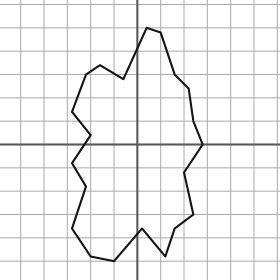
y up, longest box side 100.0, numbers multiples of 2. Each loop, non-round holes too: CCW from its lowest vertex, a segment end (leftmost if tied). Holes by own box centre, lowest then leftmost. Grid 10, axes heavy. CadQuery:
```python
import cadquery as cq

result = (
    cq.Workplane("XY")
    .moveTo(-10.0, -50.0)
    .lineTo(2.0, -36.0)
    .lineTo(12.0, -48.0)
    .lineTo(16.0, -36.0)
    .lineTo(24.0, -30.0)
    .lineTo(20.0, -12.0)
    .lineTo(28.0, 0.0)
    .lineTo(24.0, 10.0)
    .lineTo(22.0, 24.0)
    .lineTo(16.0, 30.0)
    .lineTo(10.0, 48.0)
    .lineTo(4.0, 50.0)
    .lineTo(-6.0, 28.0)
    .lineTo(-16.0, 34.0)
    .lineTo(-22.0, 30.0)
    .lineTo(-28.0, 14.0)
    .lineTo(-20.0, 4.0)
    .lineTo(-28.0, -8.0)
    .lineTo(-22.0, -18.0)
    .lineTo(-28.0, -36.0)
    .lineTo(-20.0, -48.0)
    .close()
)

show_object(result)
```